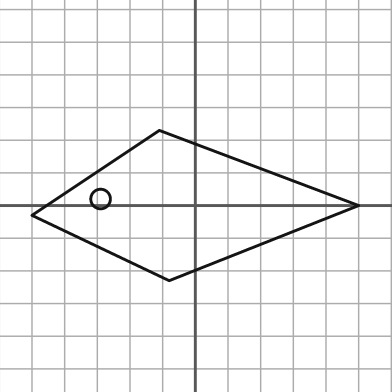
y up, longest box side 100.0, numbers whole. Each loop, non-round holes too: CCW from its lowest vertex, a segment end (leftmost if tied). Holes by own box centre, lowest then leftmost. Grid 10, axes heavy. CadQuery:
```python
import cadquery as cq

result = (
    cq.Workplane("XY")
    .moveTo(-8.0, -23.0)
    .lineTo(50.0, 0.0)
    .lineTo(-11.0, 23.0)
    .lineTo(-50.0, -3.0)
    .close()
    .moveTo(-29.0, 2.0)
    .circle(3.0)
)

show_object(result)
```